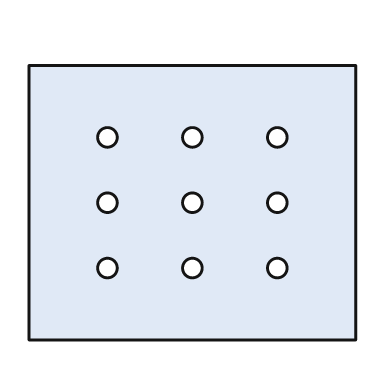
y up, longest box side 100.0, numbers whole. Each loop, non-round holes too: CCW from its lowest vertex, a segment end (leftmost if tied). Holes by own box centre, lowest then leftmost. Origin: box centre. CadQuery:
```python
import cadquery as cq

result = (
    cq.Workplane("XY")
    .moveTo(-50.0, -42.0)
    .lineTo(50.0, -42.0)
    .lineTo(50.0, 42.0)
    .lineTo(-50.0, 42.0)
    .close()
    .moveTo(-26.0, -20.0)
    .circle(3.0)
    .moveTo(0.0, -20.0)
    .circle(3.0)
    .moveTo(26.0, -20.0)
    .circle(3.0)
    .moveTo(-26.0, 0.0)
    .circle(3.0)
    .moveTo(0.0, 0.0)
    .circle(3.0)
    .moveTo(26.0, 0.0)
    .circle(3.0)
    .moveTo(-26.0, 20.0)
    .circle(3.0)
    .moveTo(0.0, 20.0)
    .circle(3.0)
    .moveTo(26.0, 20.0)
    .circle(3.0)
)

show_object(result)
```